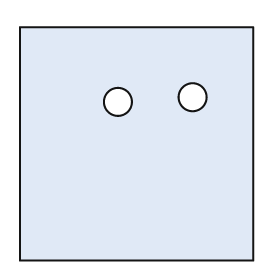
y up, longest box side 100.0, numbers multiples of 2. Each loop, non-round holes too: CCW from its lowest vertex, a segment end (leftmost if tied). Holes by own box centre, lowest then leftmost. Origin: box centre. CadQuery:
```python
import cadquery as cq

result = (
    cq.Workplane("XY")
    .moveTo(-50.0, -50.0)
    .lineTo(50.0, -50.0)
    .lineTo(50.0, 50.0)
    .lineTo(-50.0, 50.0)
    .close()
    .moveTo(-8.0, 18.0)
    .circle(6.0)
    .moveTo(24.0, 20.0)
    .circle(6.0)
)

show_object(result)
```